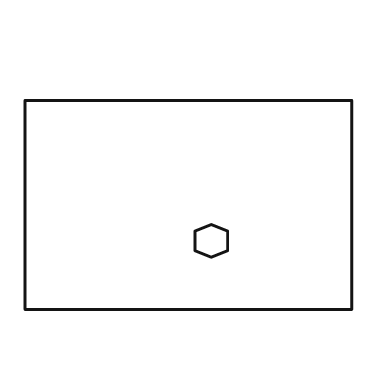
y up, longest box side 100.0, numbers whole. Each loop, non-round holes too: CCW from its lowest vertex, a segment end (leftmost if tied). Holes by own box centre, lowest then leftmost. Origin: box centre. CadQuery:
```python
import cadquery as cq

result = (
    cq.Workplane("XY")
    .moveTo(-50.0, -32.0)
    .lineTo(50.0, -32.0)
    .lineTo(50.0, 32.0)
    .lineTo(-50.0, 32.0)
    .close()
    .moveTo(7.0, -16.0)
    .lineTo(12.0, -14.0)
    .lineTo(12.0, -8.0)
    .lineTo(7.0, -6.0)
    .lineTo(2.0, -8.0)
    .lineTo(2.0, -14.0)
    .close()
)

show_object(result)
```